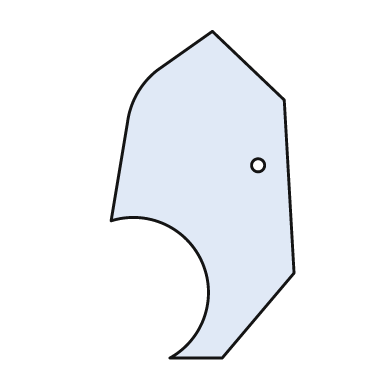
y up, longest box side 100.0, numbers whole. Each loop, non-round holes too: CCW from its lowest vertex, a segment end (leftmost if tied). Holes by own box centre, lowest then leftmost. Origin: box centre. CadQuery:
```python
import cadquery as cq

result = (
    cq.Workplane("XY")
    .moveTo(-10.0, -50.0)
    .lineTo(6.0, -50.0)
    .lineTo(28.0, -24.0)
    .lineTo(25.0, 29.0)
    .lineTo(3.0, 50.0)
    .lineTo(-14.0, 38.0)
    .threePointArc((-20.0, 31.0), (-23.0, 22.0))
    .lineTo(-28.0, -8.0)
    .threePointArc((0.0, -21.0), (-10.0, -50.0))
    .close()
    .moveTo(17.0, 9.0)
    .circle(2.0)
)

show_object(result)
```